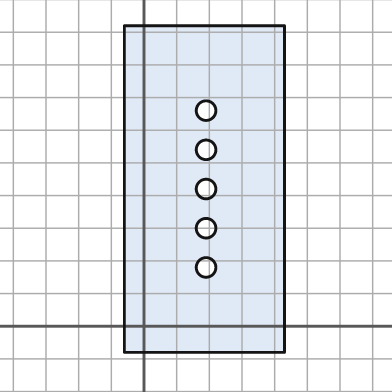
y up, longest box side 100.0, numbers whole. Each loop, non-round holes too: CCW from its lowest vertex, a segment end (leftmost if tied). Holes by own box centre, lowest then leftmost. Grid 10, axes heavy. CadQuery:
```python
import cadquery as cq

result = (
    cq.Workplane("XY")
    .moveTo(-6.0, -8.0)
    .lineTo(43.0, -8.0)
    .lineTo(43.0, 92.0)
    .lineTo(-6.0, 92.0)
    .close()
    .moveTo(19.0, 18.0)
    .circle(3.0)
    .moveTo(19.0, 30.0)
    .circle(3.0)
    .moveTo(19.0, 42.0)
    .circle(3.0)
    .moveTo(19.0, 54.0)
    .circle(3.0)
    .moveTo(19.0, 66.0)
    .circle(3.0)
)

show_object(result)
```